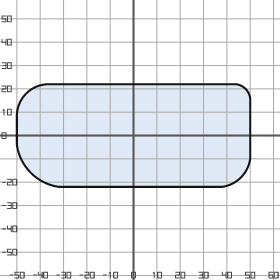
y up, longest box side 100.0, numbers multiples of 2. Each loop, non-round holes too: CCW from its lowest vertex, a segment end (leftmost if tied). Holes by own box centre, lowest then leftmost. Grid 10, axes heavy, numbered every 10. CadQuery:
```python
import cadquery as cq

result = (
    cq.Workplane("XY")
    .moveTo(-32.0, -22.0)
    .lineTo(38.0, -22.0)
    .threePointArc((46.0, -18.0), (50.0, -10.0))
    .lineTo(50.0, 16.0)
    .threePointArc((48.0, 20.0), (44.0, 22.0))
    .lineTo(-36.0, 22.0)
    .threePointArc((-46.0, 18.0), (-50.0, 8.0))
    .lineTo(-50.0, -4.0)
    .threePointArc((-44.0, -16.0), (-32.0, -22.0))
    .close()
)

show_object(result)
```